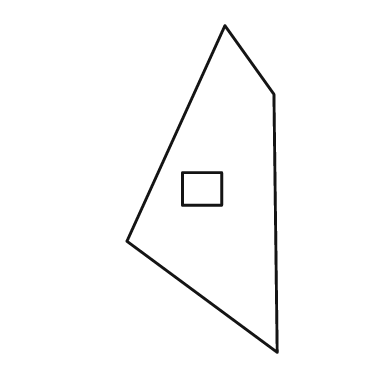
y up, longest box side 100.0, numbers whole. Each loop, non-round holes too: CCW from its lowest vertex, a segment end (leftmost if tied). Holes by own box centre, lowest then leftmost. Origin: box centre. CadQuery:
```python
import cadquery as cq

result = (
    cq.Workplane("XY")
    .moveTo(23.0, -50.0)
    .lineTo(22.0, 29.0)
    .lineTo(7.0, 50.0)
    .lineTo(-23.0, -16.0)
    .close()
    .moveTo(-6.0, -5.0)
    .lineTo(6.0, -5.0)
    .lineTo(6.0, 5.0)
    .lineTo(-6.0, 5.0)
    .close()
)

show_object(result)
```